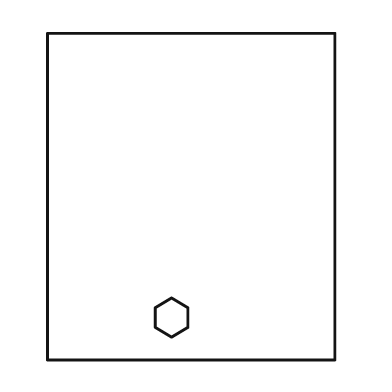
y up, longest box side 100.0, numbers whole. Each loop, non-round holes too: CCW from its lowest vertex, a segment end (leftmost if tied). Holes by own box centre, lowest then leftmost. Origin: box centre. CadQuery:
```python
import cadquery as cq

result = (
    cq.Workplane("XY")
    .moveTo(-44.0, -50.0)
    .lineTo(44.0, -50.0)
    .lineTo(44.0, 50.0)
    .lineTo(-44.0, 50.0)
    .close()
    .moveTo(-6.0, -43.0)
    .lineTo(-1.0, -40.0)
    .lineTo(-1.0, -34.0)
    .lineTo(-6.0, -31.0)
    .lineTo(-11.0, -34.0)
    .lineTo(-11.0, -40.0)
    .close()
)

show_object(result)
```